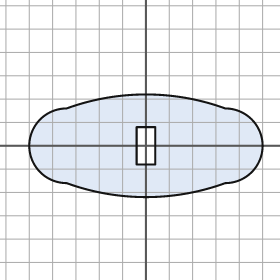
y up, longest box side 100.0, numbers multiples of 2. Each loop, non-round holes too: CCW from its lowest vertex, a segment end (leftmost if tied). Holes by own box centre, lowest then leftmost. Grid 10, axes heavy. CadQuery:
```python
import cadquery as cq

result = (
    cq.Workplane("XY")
    .moveTo(-34.0, -16.0)
    .threePointArc((0.0, -22.0), (34.0, -16.0))
    .threePointArc((50.0, 0.0), (34.0, 16.0))
    .threePointArc((0.0, 22.0), (-34.0, 16.0))
    .threePointArc((-50.0, 0.0), (-34.0, -16.0))
    .close()
    .moveTo(-4.0, -8.0)
    .lineTo(4.0, -8.0)
    .lineTo(4.0, 8.0)
    .lineTo(-4.0, 8.0)
    .close()
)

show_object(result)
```